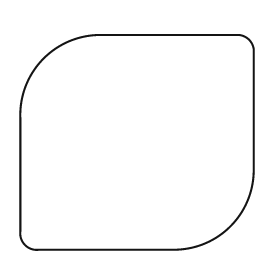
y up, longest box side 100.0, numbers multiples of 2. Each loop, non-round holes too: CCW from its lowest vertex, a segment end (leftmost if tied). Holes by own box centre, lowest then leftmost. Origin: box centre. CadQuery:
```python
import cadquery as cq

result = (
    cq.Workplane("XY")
    .moveTo(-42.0, -46.0)
    .lineTo(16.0, -46.0)
    .threePointArc((40.0, -36.0), (50.0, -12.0))
    .lineTo(50.0, 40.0)
    .threePointArc((48.0, 44.0), (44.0, 46.0))
    .lineTo(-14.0, 46.0)
    .threePointArc((-40.0, 36.0), (-50.0, 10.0))
    .lineTo(-50.0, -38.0)
    .threePointArc((-48.0, -44.0), (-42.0, -46.0))
    .close()
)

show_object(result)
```